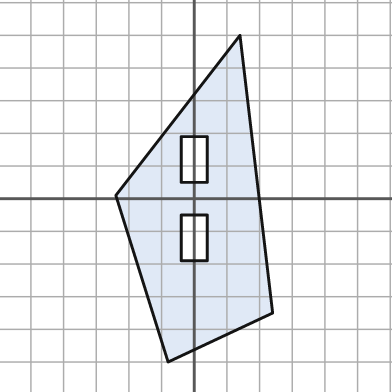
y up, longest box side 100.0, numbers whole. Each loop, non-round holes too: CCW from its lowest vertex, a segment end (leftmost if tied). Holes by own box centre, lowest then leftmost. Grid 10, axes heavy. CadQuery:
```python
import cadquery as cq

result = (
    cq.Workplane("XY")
    .moveTo(-8.0, -50.0)
    .lineTo(24.0, -35.0)
    .lineTo(14.0, 50.0)
    .lineTo(-24.0, 1.0)
    .close()
    .moveTo(-4.0, -19.0)
    .lineTo(4.0, -19.0)
    .lineTo(4.0, -5.0)
    .lineTo(-4.0, -5.0)
    .close()
    .moveTo(-4.0, 5.0)
    .lineTo(4.0, 5.0)
    .lineTo(4.0, 19.0)
    .lineTo(-4.0, 19.0)
    .close()
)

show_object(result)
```